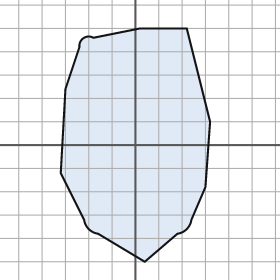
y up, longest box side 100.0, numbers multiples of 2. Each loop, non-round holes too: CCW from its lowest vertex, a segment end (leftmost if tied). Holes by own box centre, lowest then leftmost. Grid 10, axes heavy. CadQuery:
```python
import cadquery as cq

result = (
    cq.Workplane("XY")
    .moveTo(4.0, -50.0)
    .lineTo(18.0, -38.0)
    .threePointArc((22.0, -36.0), (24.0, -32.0))
    .lineTo(30.0, -18.0)
    .lineTo(32.0, 10.0)
    .lineTo(22.0, 50.0)
    .lineTo(2.0, 50.0)
    .lineTo(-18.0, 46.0)
    .threePointArc((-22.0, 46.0), (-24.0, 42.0))
    .lineTo(-30.0, 24.0)
    .lineTo(-32.0, -12.0)
    .lineTo(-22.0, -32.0)
    .threePointArc((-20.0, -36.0), (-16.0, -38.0))
    .close()
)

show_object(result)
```